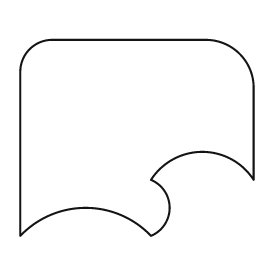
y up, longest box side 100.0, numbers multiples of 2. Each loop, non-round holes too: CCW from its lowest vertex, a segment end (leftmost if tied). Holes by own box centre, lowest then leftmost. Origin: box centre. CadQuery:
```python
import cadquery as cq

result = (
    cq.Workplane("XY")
    .moveTo(-50.0, -42.0)
    .threePointArc((-22.0, -30.0), (6.0, -42.0))
    .threePointArc((14.0, -30.0), (6.0, -18.0))
    .threePointArc((28.0, -6.0), (50.0, -18.0))
    .lineTo(50.0, 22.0)
    .threePointArc((44.0, 36.0), (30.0, 42.0))
    .lineTo(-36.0, 42.0)
    .threePointArc((-46.0, 38.0), (-50.0, 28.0))
    .close()
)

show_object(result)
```